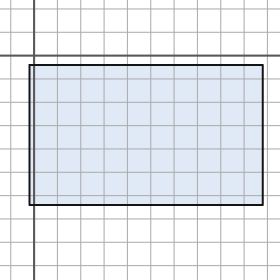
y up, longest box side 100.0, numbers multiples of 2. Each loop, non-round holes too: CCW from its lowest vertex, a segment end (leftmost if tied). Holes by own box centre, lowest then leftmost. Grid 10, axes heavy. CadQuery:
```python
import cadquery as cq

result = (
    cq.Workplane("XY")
    .moveTo(-2.0, -64.0)
    .lineTo(98.0, -64.0)
    .lineTo(98.0, -4.0)
    .lineTo(-2.0, -4.0)
    .close()
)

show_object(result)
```